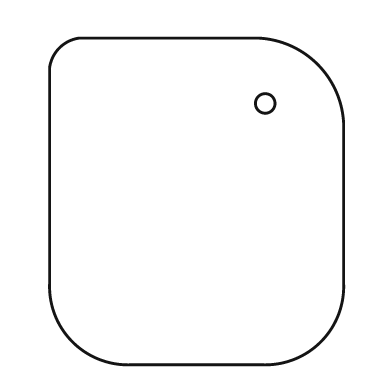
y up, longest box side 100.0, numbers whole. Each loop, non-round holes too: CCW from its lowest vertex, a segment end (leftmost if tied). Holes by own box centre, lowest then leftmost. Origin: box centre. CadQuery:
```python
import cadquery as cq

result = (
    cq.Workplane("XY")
    .moveTo(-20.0, -50.0)
    .lineTo(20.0, -50.0)
    .threePointArc((38.0, -43.0), (45.0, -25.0))
    .lineTo(45.0, 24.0)
    .threePointArc((37.0, 42.0), (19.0, 50.0))
    .lineTo(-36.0, 50.0)
    .threePointArc((-42.0, 47.0), (-45.0, 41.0))
    .lineTo(-45.0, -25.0)
    .threePointArc((-38.0, -43.0), (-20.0, -50.0))
    .close()
    .moveTo(21.0, 30.0)
    .circle(3.0)
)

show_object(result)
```